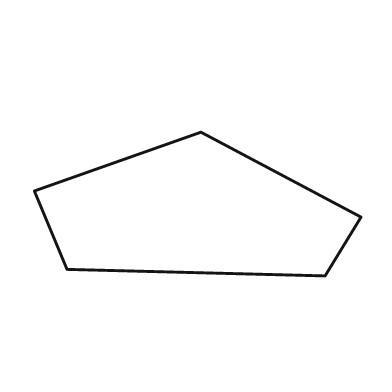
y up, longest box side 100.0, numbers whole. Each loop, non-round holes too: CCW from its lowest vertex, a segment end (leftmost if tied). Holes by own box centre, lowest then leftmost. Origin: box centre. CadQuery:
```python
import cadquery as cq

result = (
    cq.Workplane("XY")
    .moveTo(39.0, -22.0)
    .lineTo(50.0, -4.0)
    .lineTo(1.0, 22.0)
    .lineTo(-50.0, 4.0)
    .lineTo(-40.0, -20.0)
    .close()
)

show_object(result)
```